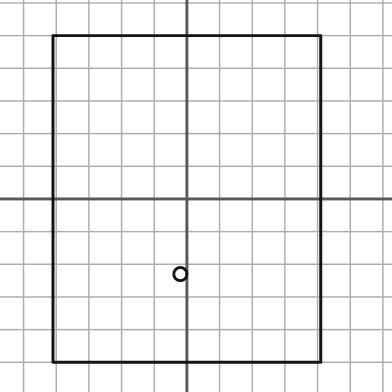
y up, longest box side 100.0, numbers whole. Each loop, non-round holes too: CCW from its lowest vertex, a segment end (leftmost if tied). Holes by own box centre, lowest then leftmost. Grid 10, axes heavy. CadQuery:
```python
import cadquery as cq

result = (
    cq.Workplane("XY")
    .moveTo(-41.0, -50.0)
    .lineTo(41.0, -50.0)
    .lineTo(41.0, 50.0)
    .lineTo(-41.0, 50.0)
    .close()
    .moveTo(-2.0, -23.0)
    .circle(2.0)
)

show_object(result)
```